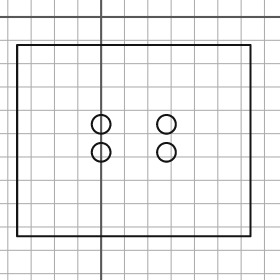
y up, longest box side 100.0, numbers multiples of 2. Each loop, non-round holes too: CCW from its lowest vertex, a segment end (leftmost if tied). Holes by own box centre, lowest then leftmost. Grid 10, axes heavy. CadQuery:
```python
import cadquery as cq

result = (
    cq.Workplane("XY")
    .moveTo(-36.0, -94.0)
    .lineTo(64.0, -94.0)
    .lineTo(64.0, -12.0)
    .lineTo(-36.0, -12.0)
    .close()
    .moveTo(0.0, -58.0)
    .circle(4.0)
    .moveTo(28.0, -58.0)
    .circle(4.0)
    .moveTo(0.0, -46.0)
    .circle(4.0)
    .moveTo(28.0, -46.0)
    .circle(4.0)
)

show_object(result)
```